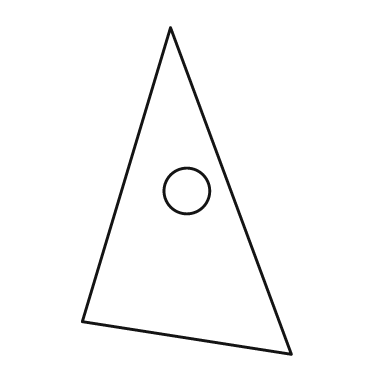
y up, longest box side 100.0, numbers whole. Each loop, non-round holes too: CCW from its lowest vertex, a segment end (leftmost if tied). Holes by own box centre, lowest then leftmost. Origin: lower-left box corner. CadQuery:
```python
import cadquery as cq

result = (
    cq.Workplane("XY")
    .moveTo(64.0, 0.0)
    .lineTo(27.0, 100.0)
    .lineTo(0.0, 10.0)
    .close()
    .moveTo(32.0, 50.0)
    .circle(7.0)
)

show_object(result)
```